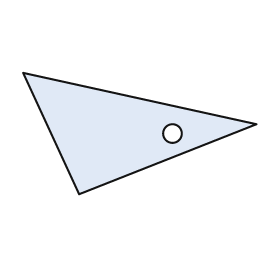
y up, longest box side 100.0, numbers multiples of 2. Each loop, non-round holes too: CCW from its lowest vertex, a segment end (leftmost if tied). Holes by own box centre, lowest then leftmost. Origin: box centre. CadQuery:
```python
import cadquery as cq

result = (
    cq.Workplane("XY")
    .moveTo(-26.0, -26.0)
    .lineTo(50.0, 4.0)
    .lineTo(-50.0, 26.0)
    .close()
    .moveTo(14.0, 0.0)
    .circle(4.0)
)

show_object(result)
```